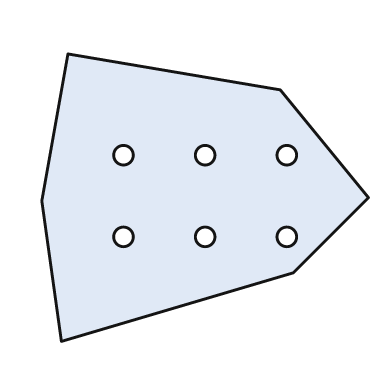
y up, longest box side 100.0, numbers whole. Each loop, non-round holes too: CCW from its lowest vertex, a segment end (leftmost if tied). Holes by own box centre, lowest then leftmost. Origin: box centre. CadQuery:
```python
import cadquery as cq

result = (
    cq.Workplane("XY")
    .moveTo(-44.0, -44.0)
    .lineTo(27.0, -23.0)
    .lineTo(50.0, 0.0)
    .lineTo(23.0, 33.0)
    .lineTo(-42.0, 44.0)
    .lineTo(-50.0, -1.0)
    .close()
    .moveTo(-25.0, -12.0)
    .circle(3.0)
    .moveTo(0.0, -12.0)
    .circle(3.0)
    .moveTo(25.0, -12.0)
    .circle(3.0)
    .moveTo(-25.0, 13.0)
    .circle(3.0)
    .moveTo(0.0, 13.0)
    .circle(3.0)
    .moveTo(25.0, 13.0)
    .circle(3.0)
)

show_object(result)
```